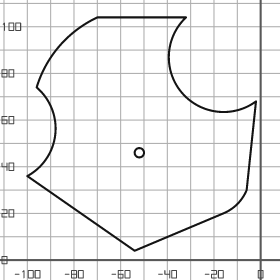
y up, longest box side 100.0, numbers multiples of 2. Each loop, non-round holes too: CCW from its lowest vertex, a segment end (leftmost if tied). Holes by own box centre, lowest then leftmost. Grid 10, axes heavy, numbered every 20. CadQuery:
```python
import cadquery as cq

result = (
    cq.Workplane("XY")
    .moveTo(-54.0, 4.0)
    .lineTo(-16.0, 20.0)
    .threePointArc((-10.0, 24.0), (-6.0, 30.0))
    .lineTo(-2.0, 68.0)
    .threePointArc((-34.0, 72.0), (-32.0, 104.0))
    .lineTo(-70.0, 104.0)
    .threePointArc((-86.0, 92.0), (-96.0, 74.0))
    .threePointArc((-88.0, 54.0), (-100.0, 36.0))
    .close()
    .moveTo(-52.0, 46.0)
    .circle(2.0)
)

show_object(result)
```